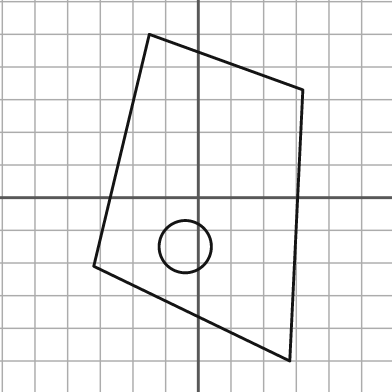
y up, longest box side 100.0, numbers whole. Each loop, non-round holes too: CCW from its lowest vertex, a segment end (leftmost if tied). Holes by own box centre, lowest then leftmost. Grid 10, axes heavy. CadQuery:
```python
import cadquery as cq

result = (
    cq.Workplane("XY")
    .moveTo(28.0, -50.0)
    .lineTo(32.0, 33.0)
    .lineTo(-15.0, 50.0)
    .lineTo(-32.0, -21.0)
    .close()
    .moveTo(-4.0, -15.0)
    .circle(8.0)
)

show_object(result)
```